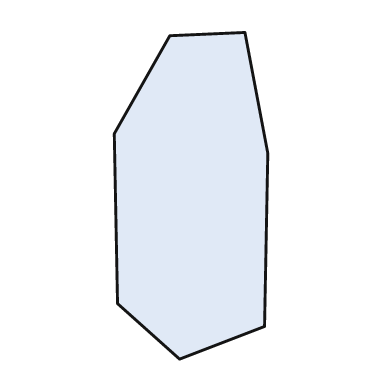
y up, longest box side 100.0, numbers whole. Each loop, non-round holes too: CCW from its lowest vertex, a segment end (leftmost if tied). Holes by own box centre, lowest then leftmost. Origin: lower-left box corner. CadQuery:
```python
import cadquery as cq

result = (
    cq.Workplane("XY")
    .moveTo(20.0, 0.0)
    .lineTo(46.0, 10.0)
    .lineTo(47.0, 63.0)
    .lineTo(40.0, 100.0)
    .lineTo(17.0, 99.0)
    .lineTo(0.0, 69.0)
    .lineTo(1.0, 17.0)
    .close()
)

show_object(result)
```